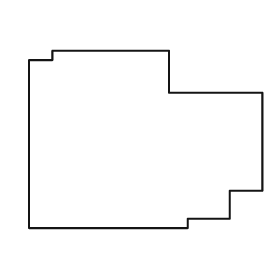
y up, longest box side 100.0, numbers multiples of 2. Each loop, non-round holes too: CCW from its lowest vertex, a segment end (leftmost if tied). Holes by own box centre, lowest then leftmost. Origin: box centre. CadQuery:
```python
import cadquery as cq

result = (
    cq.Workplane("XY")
    .moveTo(-50.0, -38.0)
    .lineTo(18.0, -38.0)
    .lineTo(18.0, -34.0)
    .lineTo(36.0, -34.0)
    .lineTo(36.0, -22.0)
    .lineTo(50.0, -22.0)
    .lineTo(50.0, 20.0)
    .lineTo(10.0, 20.0)
    .lineTo(10.0, 38.0)
    .lineTo(-40.0, 38.0)
    .lineTo(-40.0, 34.0)
    .lineTo(-50.0, 34.0)
    .close()
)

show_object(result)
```